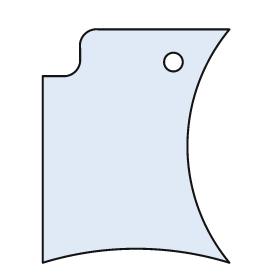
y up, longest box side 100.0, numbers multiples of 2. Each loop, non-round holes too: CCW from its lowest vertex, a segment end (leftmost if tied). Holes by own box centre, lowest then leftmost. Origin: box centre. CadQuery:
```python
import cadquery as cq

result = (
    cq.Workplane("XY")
    .moveTo(-40.0, -50.0)
    .threePointArc((0.0, -44.0), (40.0, -50.0))
    .threePointArc((22.0, 0.0), (40.0, 50.0))
    .lineTo(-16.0, 50.0)
    .threePointArc((-22.0, 48.0), (-24.0, 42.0))
    .lineTo(-24.0, 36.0)
    .threePointArc((-26.0, 32.0), (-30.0, 30.0))
    .lineTo(-40.0, 30.0)
    .close()
    .moveTo(16.0, 36.0)
    .circle(4.0)
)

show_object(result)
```